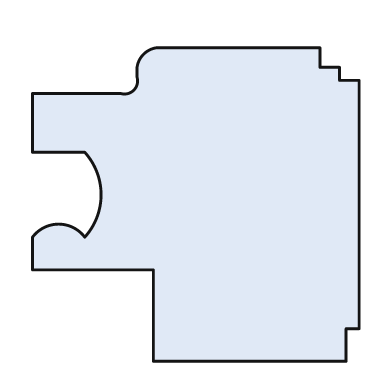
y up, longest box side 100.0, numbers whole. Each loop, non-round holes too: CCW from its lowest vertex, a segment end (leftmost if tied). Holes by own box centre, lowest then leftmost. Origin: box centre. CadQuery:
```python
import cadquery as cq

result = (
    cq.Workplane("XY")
    .moveTo(-13.0, -48.0)
    .lineTo(46.0, -48.0)
    .lineTo(46.0, -38.0)
    .lineTo(50.0, -38.0)
    .lineTo(50.0, 38.0)
    .lineTo(44.0, 38.0)
    .lineTo(44.0, 42.0)
    .lineTo(38.0, 42.0)
    .lineTo(38.0, 48.0)
    .lineTo(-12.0, 48.0)
    .threePointArc((-16.0, 46.0), (-18.0, 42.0))
    .lineTo(-18.0, 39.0)
    .threePointArc((-19.0, 35.0), (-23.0, 34.0))
    .lineTo(-50.0, 34.0)
    .lineTo(-50.0, 16.0)
    .lineTo(-34.0, 16.0)
    .threePointArc((-29.0, 3.0), (-34.0, -10.0))
    .threePointArc((-42.0, -6.0), (-50.0, -10.0))
    .lineTo(-50.0, -20.0)
    .lineTo(-13.0, -20.0)
    .close()
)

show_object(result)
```